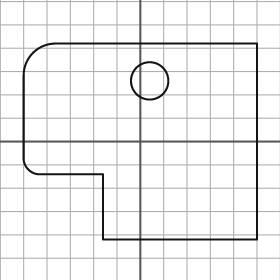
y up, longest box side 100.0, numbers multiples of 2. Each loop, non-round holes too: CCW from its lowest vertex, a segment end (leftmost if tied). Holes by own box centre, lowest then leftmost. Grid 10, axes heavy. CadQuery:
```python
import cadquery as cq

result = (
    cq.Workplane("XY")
    .moveTo(-16.0, -42.0)
    .lineTo(50.0, -42.0)
    .lineTo(50.0, 42.0)
    .lineTo(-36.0, 42.0)
    .threePointArc((-46.0, 38.0), (-50.0, 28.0))
    .lineTo(-50.0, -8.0)
    .threePointArc((-48.0, -12.0), (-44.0, -14.0))
    .lineTo(-16.0, -14.0)
    .close()
    .moveTo(4.0, 26.0)
    .circle(8.0)
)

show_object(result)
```